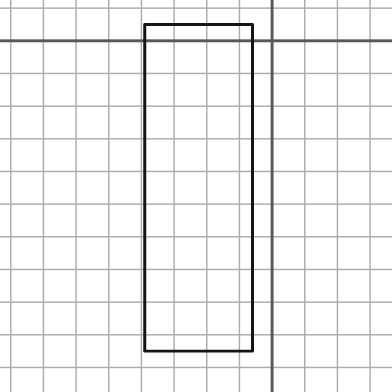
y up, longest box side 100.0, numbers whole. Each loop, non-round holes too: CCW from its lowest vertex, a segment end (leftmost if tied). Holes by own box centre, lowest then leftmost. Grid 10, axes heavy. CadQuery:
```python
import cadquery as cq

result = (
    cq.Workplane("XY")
    .moveTo(-39.0, -95.0)
    .lineTo(-6.0, -95.0)
    .lineTo(-6.0, 5.0)
    .lineTo(-39.0, 5.0)
    .close()
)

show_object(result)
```